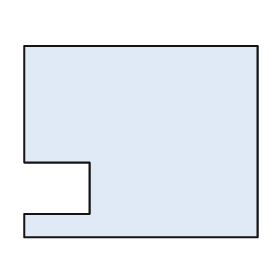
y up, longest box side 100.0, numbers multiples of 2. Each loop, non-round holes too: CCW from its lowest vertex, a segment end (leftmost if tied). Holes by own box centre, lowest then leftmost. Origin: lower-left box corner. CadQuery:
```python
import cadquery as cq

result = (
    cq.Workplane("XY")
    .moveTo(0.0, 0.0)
    .lineTo(100.0, 0.0)
    .lineTo(100.0, 82.0)
    .lineTo(0.0, 82.0)
    .lineTo(0.0, 32.0)
    .lineTo(28.0, 32.0)
    .lineTo(28.0, 10.0)
    .lineTo(0.0, 10.0)
    .close()
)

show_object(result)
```